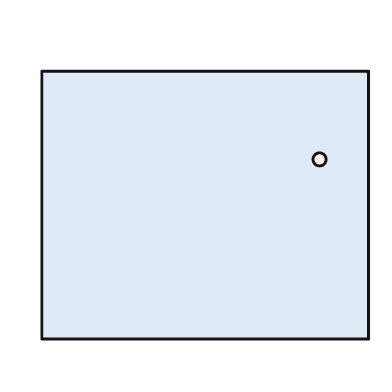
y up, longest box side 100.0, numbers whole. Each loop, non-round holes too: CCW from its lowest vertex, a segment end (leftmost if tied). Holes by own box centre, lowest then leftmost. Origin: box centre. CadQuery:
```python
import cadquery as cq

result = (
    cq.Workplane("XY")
    .moveTo(-50.0, -41.0)
    .lineTo(50.0, -41.0)
    .lineTo(50.0, 41.0)
    .lineTo(-50.0, 41.0)
    .close()
    .moveTo(35.0, 14.0)
    .circle(2.0)
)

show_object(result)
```